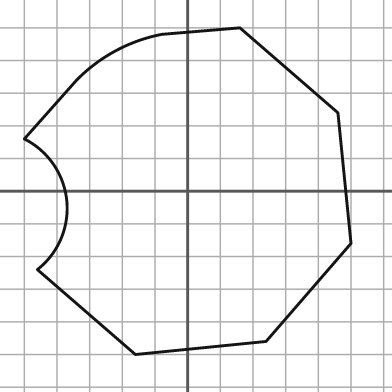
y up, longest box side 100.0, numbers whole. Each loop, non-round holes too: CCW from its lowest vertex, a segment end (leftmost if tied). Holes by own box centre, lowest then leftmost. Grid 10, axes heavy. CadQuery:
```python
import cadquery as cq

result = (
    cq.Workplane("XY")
    .moveTo(-16.0, -50.0)
    .lineTo(24.0, -46.0)
    .lineTo(50.0, -16.0)
    .lineTo(46.0, 24.0)
    .lineTo(16.0, 50.0)
    .lineTo(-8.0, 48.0)
    .threePointArc((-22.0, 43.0), (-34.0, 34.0))
    .lineTo(-50.0, 16.0)
    .threePointArc((-37.0, -3.0), (-46.0, -24.0))
    .close()
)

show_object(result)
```